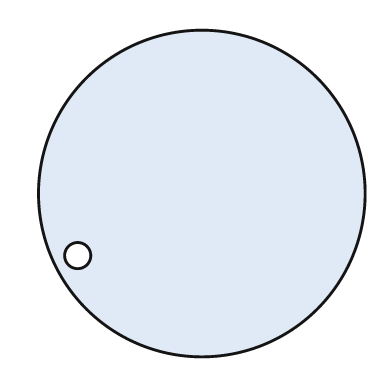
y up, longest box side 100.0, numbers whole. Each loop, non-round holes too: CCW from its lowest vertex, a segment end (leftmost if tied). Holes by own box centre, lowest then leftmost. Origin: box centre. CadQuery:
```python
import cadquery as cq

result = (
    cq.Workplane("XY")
    .moveTo(0.0, 0.0)
    .circle(50.0)
    .moveTo(-38.0, -19.0)
    .circle(4.0)
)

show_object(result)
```